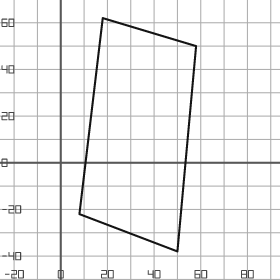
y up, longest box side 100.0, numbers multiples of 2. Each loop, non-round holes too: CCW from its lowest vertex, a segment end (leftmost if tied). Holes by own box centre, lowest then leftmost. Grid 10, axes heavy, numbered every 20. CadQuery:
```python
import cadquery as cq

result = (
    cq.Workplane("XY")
    .moveTo(50.0, -38.0)
    .lineTo(58.0, 50.0)
    .lineTo(18.0, 62.0)
    .lineTo(8.0, -22.0)
    .close()
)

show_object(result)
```